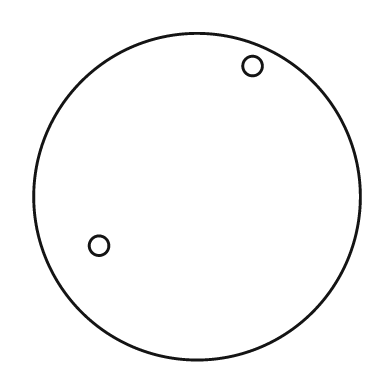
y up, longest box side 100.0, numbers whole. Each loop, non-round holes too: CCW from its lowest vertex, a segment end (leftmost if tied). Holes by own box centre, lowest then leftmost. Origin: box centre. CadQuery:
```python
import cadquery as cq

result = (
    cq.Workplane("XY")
    .moveTo(0.0, 0.0)
    .circle(50.0)
    .moveTo(-30.0, -15.0)
    .circle(3.0)
    .moveTo(17.0, 40.0)
    .circle(3.0)
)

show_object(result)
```